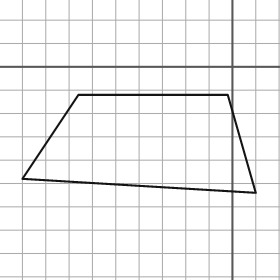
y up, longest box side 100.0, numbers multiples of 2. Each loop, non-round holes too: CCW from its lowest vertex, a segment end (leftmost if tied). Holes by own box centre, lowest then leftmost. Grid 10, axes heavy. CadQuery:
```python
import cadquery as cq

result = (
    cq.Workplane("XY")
    .moveTo(10.0, -54.0)
    .lineTo(-2.0, -12.0)
    .lineTo(-66.0, -12.0)
    .lineTo(-90.0, -48.0)
    .close()
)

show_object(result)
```